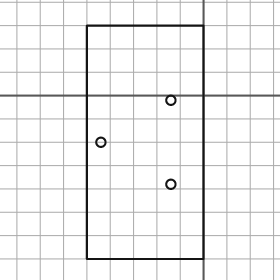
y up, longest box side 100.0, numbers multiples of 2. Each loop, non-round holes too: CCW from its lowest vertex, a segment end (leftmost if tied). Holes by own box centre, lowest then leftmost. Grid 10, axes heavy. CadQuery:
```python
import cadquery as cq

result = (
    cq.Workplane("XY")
    .moveTo(-50.0, -70.0)
    .lineTo(0.0, -70.0)
    .lineTo(0.0, 30.0)
    .lineTo(-50.0, 30.0)
    .close()
    .moveTo(-14.0, -38.0)
    .circle(2.0)
    .moveTo(-44.0, -20.0)
    .circle(2.0)
    .moveTo(-14.0, -2.0)
    .circle(2.0)
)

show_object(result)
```